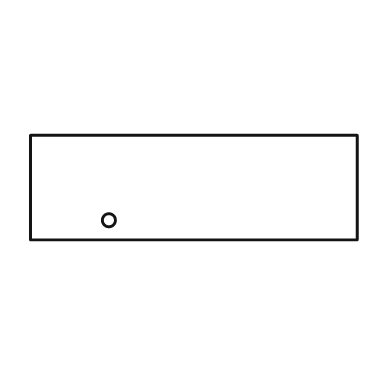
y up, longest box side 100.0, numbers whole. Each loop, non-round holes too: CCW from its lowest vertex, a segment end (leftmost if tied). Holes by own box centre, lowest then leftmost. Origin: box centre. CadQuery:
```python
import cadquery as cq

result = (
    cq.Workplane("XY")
    .moveTo(-50.0, -16.0)
    .lineTo(50.0, -16.0)
    .lineTo(50.0, 16.0)
    .lineTo(-50.0, 16.0)
    .close()
    .moveTo(-26.0, -10.0)
    .circle(2.0)
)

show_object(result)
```